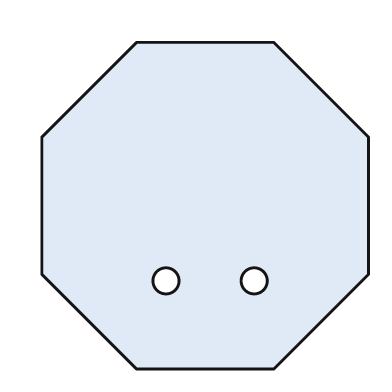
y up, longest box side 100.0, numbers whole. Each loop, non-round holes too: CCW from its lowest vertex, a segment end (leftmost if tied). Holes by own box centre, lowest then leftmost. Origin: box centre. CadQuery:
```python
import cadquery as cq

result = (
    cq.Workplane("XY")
    .moveTo(-21.0, -50.0)
    .lineTo(21.0, -50.0)
    .lineTo(50.0, -21.0)
    .lineTo(50.0, 21.0)
    .lineTo(21.0, 50.0)
    .lineTo(-21.0, 50.0)
    .lineTo(-50.0, 21.0)
    .lineTo(-50.0, -21.0)
    .close()
    .moveTo(-12.0, -23.0)
    .circle(4.0)
    .moveTo(15.0, -23.0)
    .circle(4.0)
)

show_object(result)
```